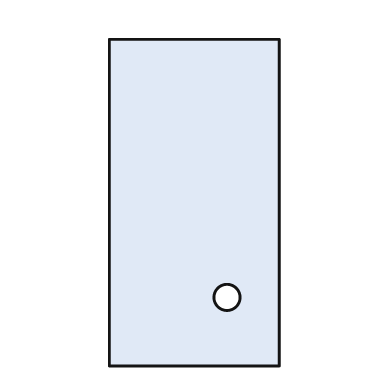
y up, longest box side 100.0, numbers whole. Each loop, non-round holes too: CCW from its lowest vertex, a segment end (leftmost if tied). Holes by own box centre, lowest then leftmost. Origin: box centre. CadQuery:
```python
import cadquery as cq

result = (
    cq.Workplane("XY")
    .moveTo(-26.0, -50.0)
    .lineTo(26.0, -50.0)
    .lineTo(26.0, 50.0)
    .lineTo(-26.0, 50.0)
    .close()
    .moveTo(10.0, -29.0)
    .circle(4.0)
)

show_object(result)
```